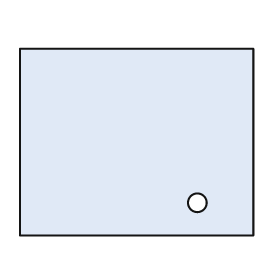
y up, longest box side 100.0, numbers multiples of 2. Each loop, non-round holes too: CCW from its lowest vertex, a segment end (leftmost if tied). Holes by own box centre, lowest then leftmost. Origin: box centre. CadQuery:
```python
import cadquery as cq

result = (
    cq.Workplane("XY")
    .moveTo(-50.0, -40.0)
    .lineTo(50.0, -40.0)
    .lineTo(50.0, 40.0)
    .lineTo(-50.0, 40.0)
    .close()
    .moveTo(26.0, -26.0)
    .circle(4.0)
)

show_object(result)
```